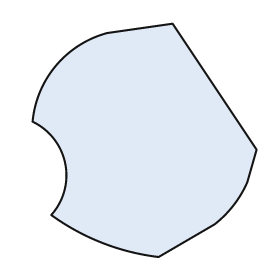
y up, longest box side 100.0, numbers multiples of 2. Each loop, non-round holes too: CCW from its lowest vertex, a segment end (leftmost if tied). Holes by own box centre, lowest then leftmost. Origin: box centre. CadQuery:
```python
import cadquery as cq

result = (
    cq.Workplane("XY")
    .moveTo(6.0, -50.0)
    .lineTo(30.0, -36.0)
    .threePointArc((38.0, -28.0), (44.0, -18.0))
    .lineTo(48.0, -4.0)
    .lineTo(12.0, 50.0)
    .lineTo(-16.0, 46.0)
    .threePointArc((-38.0, 32.0), (-48.0, 8.0))
    .threePointArc((-34.0, -10.0), (-40.0, -32.0))
    .threePointArc((-18.0, -44.0), (6.0, -50.0))
    .close()
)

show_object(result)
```